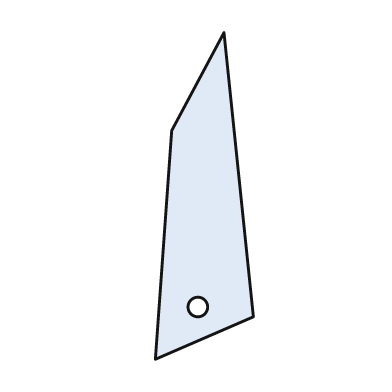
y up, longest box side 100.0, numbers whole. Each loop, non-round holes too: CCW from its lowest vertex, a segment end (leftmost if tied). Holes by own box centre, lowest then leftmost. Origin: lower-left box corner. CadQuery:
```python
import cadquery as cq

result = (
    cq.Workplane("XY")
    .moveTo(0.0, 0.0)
    .lineTo(30.0, 13.0)
    .lineTo(21.0, 100.0)
    .lineTo(5.0, 70.0)
    .close()
    .moveTo(13.0, 16.0)
    .circle(3.0)
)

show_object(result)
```